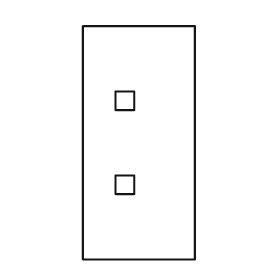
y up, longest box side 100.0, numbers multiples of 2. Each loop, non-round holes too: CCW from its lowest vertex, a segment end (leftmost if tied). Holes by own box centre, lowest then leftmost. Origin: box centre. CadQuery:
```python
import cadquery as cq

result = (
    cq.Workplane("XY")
    .moveTo(-24.0, -50.0)
    .lineTo(24.0, -50.0)
    .lineTo(24.0, 50.0)
    .lineTo(-24.0, 50.0)
    .close()
    .moveTo(-10.0, -22.0)
    .lineTo(-2.0, -22.0)
    .lineTo(-2.0, -14.0)
    .lineTo(-10.0, -14.0)
    .close()
    .moveTo(-10.0, 14.0)
    .lineTo(-2.0, 14.0)
    .lineTo(-2.0, 22.0)
    .lineTo(-10.0, 22.0)
    .close()
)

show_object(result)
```